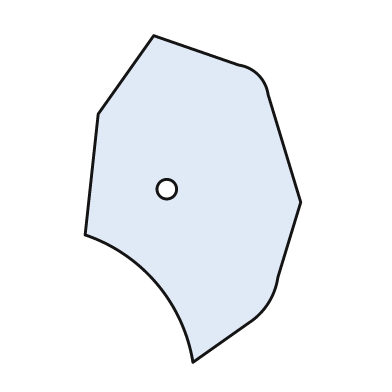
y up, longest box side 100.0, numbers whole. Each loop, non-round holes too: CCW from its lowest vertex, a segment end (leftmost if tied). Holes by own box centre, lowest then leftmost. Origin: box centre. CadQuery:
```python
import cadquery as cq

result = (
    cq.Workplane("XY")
    .moveTo(0.0, -50.0)
    .lineTo(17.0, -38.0)
    .threePointArc((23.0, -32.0), (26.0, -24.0))
    .lineTo(33.0, -1.0)
    .lineTo(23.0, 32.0)
    .threePointArc((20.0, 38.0), (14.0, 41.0))
    .lineTo(-12.0, 50.0)
    .lineTo(-29.0, 26.0)
    .lineTo(-33.0, -11.0)
    .threePointArc((-11.0, -26.0), (0.0, -50.0))
    .close()
    .moveTo(-8.0, 3.0)
    .circle(3.0)
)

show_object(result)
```